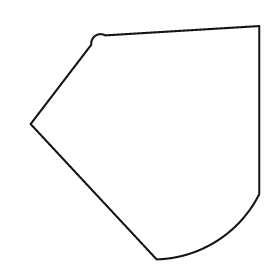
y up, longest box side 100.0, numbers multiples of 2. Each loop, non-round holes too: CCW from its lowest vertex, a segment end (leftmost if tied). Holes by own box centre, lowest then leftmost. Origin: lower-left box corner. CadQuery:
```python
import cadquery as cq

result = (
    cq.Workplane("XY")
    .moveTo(54.0, 0.0)
    .threePointArc((80.0, 8.0), (98.0, 28.0))
    .lineTo(98.0, 100.0)
    .lineTo(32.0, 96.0)
    .threePointArc((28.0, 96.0), (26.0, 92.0))
    .lineTo(0.0, 58.0)
    .close()
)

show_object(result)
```